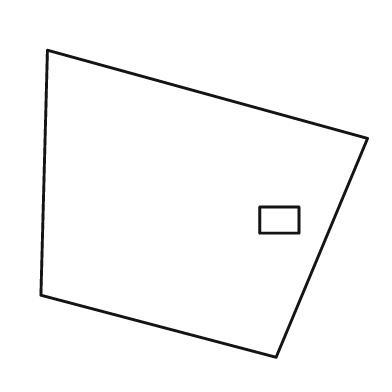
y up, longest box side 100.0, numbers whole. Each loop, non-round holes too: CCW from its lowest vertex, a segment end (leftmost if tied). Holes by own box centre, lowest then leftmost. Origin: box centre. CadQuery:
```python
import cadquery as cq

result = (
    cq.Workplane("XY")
    .moveTo(22.0, -47.0)
    .lineTo(50.0, 20.0)
    .lineTo(-48.0, 47.0)
    .lineTo(-50.0, -28.0)
    .close()
    .moveTo(17.0, -9.0)
    .lineTo(29.0, -9.0)
    .lineTo(29.0, -1.0)
    .lineTo(17.0, -1.0)
    .close()
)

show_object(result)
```